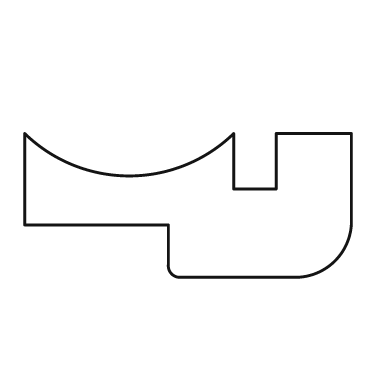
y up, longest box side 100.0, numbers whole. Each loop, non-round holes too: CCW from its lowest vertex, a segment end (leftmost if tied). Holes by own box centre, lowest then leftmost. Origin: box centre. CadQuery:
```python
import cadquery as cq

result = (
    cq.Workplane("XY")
    .moveTo(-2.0, -22.0)
    .lineTo(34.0, -22.0)
    .threePointArc((45.0, -17.0), (50.0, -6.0))
    .lineTo(50.0, 22.0)
    .lineTo(27.0, 22.0)
    .lineTo(27.0, 5.0)
    .lineTo(14.0, 5.0)
    .lineTo(14.0, 22.0)
    .threePointArc((-18.0, 9.0), (-50.0, 22.0))
    .lineTo(-50.0, -6.0)
    .lineTo(-6.0, -6.0)
    .lineTo(-6.0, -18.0)
    .threePointArc((-5.0, -21.0), (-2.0, -22.0))
    .close()
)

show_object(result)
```